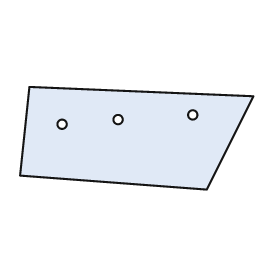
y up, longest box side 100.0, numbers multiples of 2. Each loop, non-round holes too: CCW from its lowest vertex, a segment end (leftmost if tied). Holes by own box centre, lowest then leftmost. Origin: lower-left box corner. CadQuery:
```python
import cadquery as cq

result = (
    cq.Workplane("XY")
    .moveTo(80.0, 0.0)
    .lineTo(100.0, 40.0)
    .lineTo(4.0, 44.0)
    .lineTo(0.0, 6.0)
    .close()
    .moveTo(18.0, 28.0)
    .circle(2.0)
    .moveTo(42.0, 30.0)
    .circle(2.0)
    .moveTo(74.0, 32.0)
    .circle(2.0)
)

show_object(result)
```